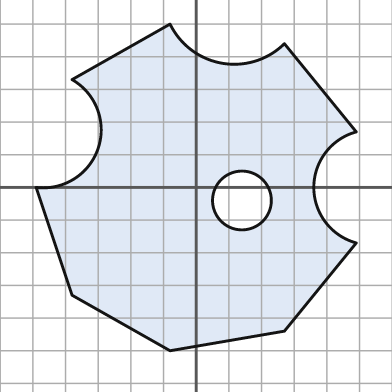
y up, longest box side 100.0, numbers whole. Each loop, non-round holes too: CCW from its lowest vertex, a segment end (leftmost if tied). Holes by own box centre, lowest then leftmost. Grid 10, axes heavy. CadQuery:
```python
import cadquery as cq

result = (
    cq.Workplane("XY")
    .moveTo(-8.0, -50.0)
    .lineTo(27.0, -44.0)
    .lineTo(49.0, -17.0)
    .threePointArc((36.0, 0.0), (49.0, 17.0))
    .lineTo(27.0, 44.0)
    .threePointArc((8.0, 38.0), (-8.0, 50.0))
    .lineTo(-38.0, 33.0)
    .threePointArc((-30.0, 12.0), (-49.0, 0.0))
    .lineTo(-38.0, -33.0)
    .close()
    .moveTo(14.0, -4.0)
    .circle(9.0)
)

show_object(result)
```